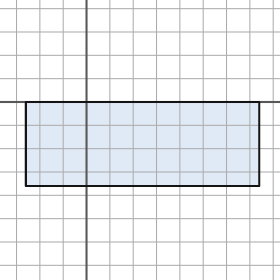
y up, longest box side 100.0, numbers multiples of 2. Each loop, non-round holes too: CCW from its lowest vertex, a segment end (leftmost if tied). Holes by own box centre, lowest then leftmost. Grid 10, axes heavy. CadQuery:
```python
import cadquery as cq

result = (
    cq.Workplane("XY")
    .moveTo(-26.0, -36.0)
    .lineTo(74.0, -36.0)
    .lineTo(74.0, 0.0)
    .lineTo(-26.0, 0.0)
    .close()
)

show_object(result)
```